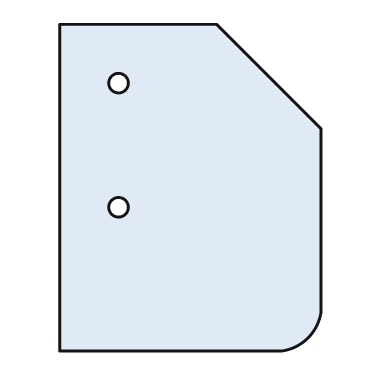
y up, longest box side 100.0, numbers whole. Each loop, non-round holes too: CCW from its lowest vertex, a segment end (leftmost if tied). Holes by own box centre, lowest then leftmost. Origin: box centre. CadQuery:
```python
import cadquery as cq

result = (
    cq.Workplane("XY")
    .moveTo(-40.0, -50.0)
    .lineTo(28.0, -50.0)
    .threePointArc((36.0, -46.0), (40.0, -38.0))
    .lineTo(40.0, 18.0)
    .lineTo(8.0, 50.0)
    .lineTo(-40.0, 50.0)
    .close()
    .moveTo(-22.0, -6.0)
    .circle(3.0)
    .moveTo(-22.0, 32.0)
    .circle(3.0)
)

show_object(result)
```